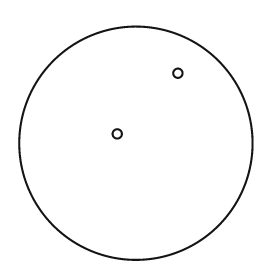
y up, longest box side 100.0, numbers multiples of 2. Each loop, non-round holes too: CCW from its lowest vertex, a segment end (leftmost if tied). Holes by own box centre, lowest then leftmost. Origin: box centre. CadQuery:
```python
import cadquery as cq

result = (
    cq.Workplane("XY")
    .moveTo(0.0, 0.0)
    .circle(50.0)
    .moveTo(-8.0, 4.0)
    .circle(2.0)
    .moveTo(18.0, 30.0)
    .circle(2.0)
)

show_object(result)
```